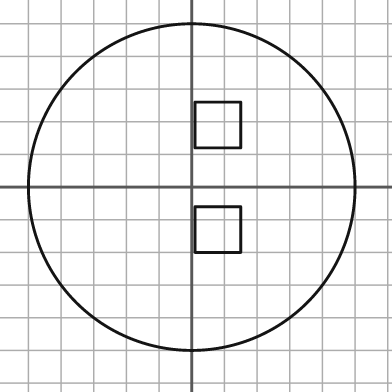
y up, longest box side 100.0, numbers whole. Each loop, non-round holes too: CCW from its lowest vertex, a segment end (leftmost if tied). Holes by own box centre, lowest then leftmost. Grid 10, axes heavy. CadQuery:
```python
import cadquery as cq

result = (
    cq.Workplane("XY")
    .moveTo(0.0, 0.0)
    .circle(50.0)
    .moveTo(1.0, -20.0)
    .lineTo(15.0, -20.0)
    .lineTo(15.0, -6.0)
    .lineTo(1.0, -6.0)
    .close()
    .moveTo(1.0, 12.0)
    .lineTo(15.0, 12.0)
    .lineTo(15.0, 26.0)
    .lineTo(1.0, 26.0)
    .close()
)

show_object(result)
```